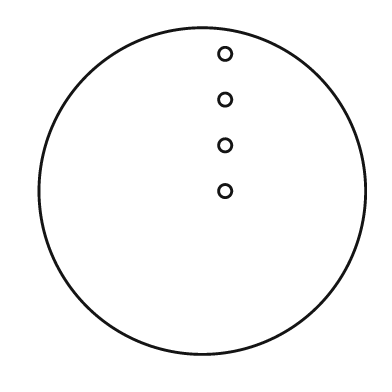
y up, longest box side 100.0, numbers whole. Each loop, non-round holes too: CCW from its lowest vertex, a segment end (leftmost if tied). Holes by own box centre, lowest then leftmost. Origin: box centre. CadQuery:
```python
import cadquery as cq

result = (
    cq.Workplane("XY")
    .moveTo(0.0, 0.0)
    .circle(50.0)
    .moveTo(7.0, 0.0)
    .circle(2.0)
    .moveTo(7.0, 14.0)
    .circle(2.0)
    .moveTo(7.0, 28.0)
    .circle(2.0)
    .moveTo(7.0, 42.0)
    .circle(2.0)
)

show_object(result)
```